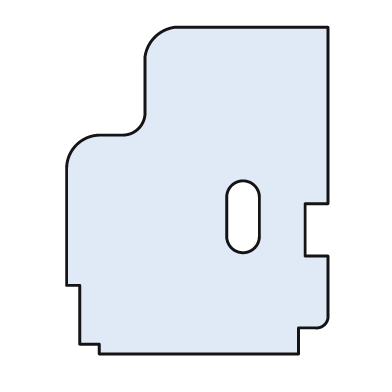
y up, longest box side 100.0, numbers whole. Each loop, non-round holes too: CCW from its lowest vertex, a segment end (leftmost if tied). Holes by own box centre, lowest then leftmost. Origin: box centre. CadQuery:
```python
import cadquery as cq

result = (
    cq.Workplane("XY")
    .moveTo(-30.0, -50.0)
    .lineTo(31.0, -50.0)
    .lineTo(31.0, -42.0)
    .lineTo(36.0, -42.0)
    .threePointArc((39.0, -41.0), (40.0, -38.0))
    .lineTo(40.0, -20.0)
    .lineTo(33.0, -20.0)
    .lineTo(33.0, -4.0)
    .lineTo(40.0, -4.0)
    .lineTo(40.0, 50.0)
    .lineTo(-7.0, 50.0)
    .threePointArc((-13.0, 47.0), (-16.0, 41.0))
    .lineTo(-16.0, 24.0)
    .threePointArc((-18.0, 19.0), (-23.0, 17.0))
    .lineTo(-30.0, 17.0)
    .threePointArc((-37.0, 14.0), (-40.0, 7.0))
    .lineTo(-40.0, -29.0)
    .lineTo(-36.0, -29.0)
    .lineTo(-36.0, -47.0)
    .lineTo(-30.0, -47.0)
    .close()
    .moveTo(9.0, -14.0)
    .threePointArc((14.0, -19.0), (19.0, -14.0))
    .lineTo(19.0, -2.0)
    .threePointArc((14.0, 3.0), (9.0, -2.0))
    .close()
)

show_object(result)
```